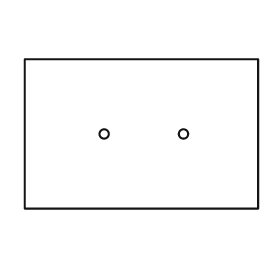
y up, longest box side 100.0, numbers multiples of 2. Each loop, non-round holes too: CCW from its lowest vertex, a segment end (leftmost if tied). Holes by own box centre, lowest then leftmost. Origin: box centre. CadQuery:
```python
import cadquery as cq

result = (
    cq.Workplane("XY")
    .moveTo(-50.0, -32.0)
    .lineTo(50.0, -32.0)
    .lineTo(50.0, 32.0)
    .lineTo(-50.0, 32.0)
    .close()
    .moveTo(-16.0, 0.0)
    .circle(2.0)
    .moveTo(18.0, 0.0)
    .circle(2.0)
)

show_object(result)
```